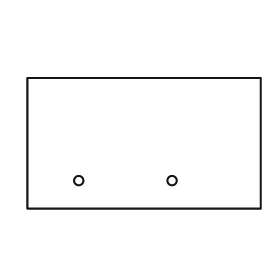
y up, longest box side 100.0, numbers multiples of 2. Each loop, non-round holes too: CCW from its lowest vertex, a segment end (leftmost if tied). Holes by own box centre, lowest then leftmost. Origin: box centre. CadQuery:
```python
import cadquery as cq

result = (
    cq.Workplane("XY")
    .moveTo(-50.0, -28.0)
    .lineTo(50.0, -28.0)
    .lineTo(50.0, 28.0)
    .lineTo(-50.0, 28.0)
    .close()
    .moveTo(-28.0, -16.0)
    .circle(2.0)
    .moveTo(12.0, -16.0)
    .circle(2.0)
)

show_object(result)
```